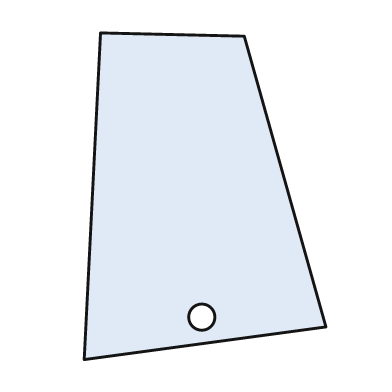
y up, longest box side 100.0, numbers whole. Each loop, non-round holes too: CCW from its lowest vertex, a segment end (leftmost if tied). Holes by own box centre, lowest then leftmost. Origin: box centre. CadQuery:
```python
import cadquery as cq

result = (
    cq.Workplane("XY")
    .moveTo(-37.0, -50.0)
    .lineTo(37.0, -40.0)
    .lineTo(12.0, 49.0)
    .lineTo(-32.0, 50.0)
    .close()
    .moveTo(-1.0, -37.0)
    .circle(4.0)
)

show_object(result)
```